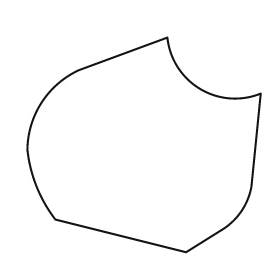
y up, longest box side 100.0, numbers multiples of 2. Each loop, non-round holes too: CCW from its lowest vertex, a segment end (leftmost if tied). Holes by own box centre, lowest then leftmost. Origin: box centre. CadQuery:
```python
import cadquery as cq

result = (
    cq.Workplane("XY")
    .moveTo(18.0, -46.0)
    .lineTo(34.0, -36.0)
    .threePointArc((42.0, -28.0), (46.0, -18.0))
    .lineTo(50.0, 22.0)
    .threePointArc((24.0, 24.0), (10.0, 46.0))
    .lineTo(-28.0, 32.0)
    .threePointArc((-44.0, 18.0), (-50.0, -2.0))
    .threePointArc((-46.0, -18.0), (-38.0, -32.0))
    .close()
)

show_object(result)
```